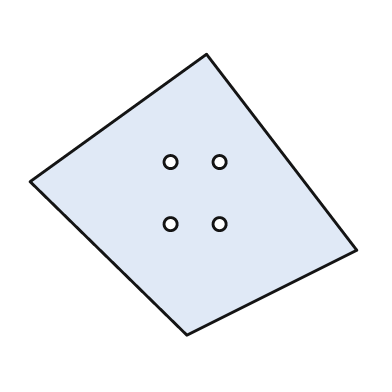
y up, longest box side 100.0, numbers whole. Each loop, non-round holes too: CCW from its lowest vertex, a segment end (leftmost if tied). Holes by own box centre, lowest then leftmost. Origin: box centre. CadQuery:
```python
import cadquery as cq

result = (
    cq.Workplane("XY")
    .moveTo(-2.0, -43.0)
    .lineTo(50.0, -17.0)
    .lineTo(4.0, 43.0)
    .lineTo(-50.0, 4.0)
    .close()
    .moveTo(-7.0, -9.0)
    .circle(2.0)
    .moveTo(8.0, -9.0)
    .circle(2.0)
    .moveTo(-7.0, 10.0)
    .circle(2.0)
    .moveTo(8.0, 10.0)
    .circle(2.0)
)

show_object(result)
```